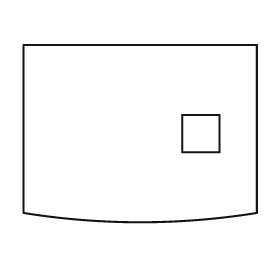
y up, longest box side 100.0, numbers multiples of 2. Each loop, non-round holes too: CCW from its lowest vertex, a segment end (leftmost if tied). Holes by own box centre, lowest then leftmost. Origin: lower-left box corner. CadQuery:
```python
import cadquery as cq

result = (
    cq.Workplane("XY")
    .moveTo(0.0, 4.0)
    .threePointArc((50.0, 0.0), (100.0, 4.0))
    .lineTo(100.0, 76.0)
    .lineTo(0.0, 76.0)
    .close()
    .moveTo(68.0, 30.0)
    .lineTo(84.0, 30.0)
    .lineTo(84.0, 46.0)
    .lineTo(68.0, 46.0)
    .close()
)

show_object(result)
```